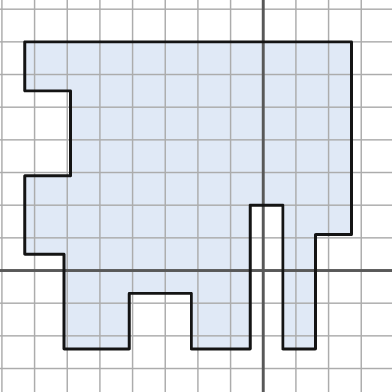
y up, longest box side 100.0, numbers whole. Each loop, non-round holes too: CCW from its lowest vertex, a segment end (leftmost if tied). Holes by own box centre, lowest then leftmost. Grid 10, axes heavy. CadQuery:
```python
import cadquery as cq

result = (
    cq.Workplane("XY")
    .moveTo(-61.0, -24.0)
    .lineTo(-41.0, -24.0)
    .lineTo(-41.0, -7.0)
    .lineTo(-22.0, -7.0)
    .lineTo(-22.0, -24.0)
    .lineTo(-4.0, -24.0)
    .lineTo(-4.0, 20.0)
    .lineTo(6.0, 20.0)
    .lineTo(6.0, -24.0)
    .lineTo(16.0, -24.0)
    .lineTo(16.0, 11.0)
    .lineTo(27.0, 11.0)
    .lineTo(27.0, 70.0)
    .lineTo(-73.0, 70.0)
    .lineTo(-73.0, 55.0)
    .lineTo(-59.0, 55.0)
    .lineTo(-59.0, 29.0)
    .lineTo(-73.0, 29.0)
    .lineTo(-73.0, 5.0)
    .lineTo(-61.0, 5.0)
    .close()
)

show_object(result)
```